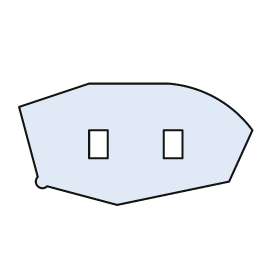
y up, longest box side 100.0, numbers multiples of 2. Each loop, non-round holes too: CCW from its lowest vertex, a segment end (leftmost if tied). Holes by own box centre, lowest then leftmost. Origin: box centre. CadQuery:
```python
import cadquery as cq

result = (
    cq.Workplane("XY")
    .moveTo(-8.0, -26.0)
    .lineTo(40.0, -16.0)
    .lineTo(50.0, 6.0)
    .threePointArc((34.0, 20.0), (14.0, 26.0))
    .lineTo(-20.0, 26.0)
    .lineTo(-50.0, 16.0)
    .lineTo(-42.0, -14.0)
    .threePointArc((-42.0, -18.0), (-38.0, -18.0))
    .close()
    .moveTo(-20.0, -6.0)
    .lineTo(-12.0, -6.0)
    .lineTo(-12.0, 6.0)
    .lineTo(-20.0, 6.0)
    .close()
    .moveTo(12.0, -6.0)
    .lineTo(20.0, -6.0)
    .lineTo(20.0, 6.0)
    .lineTo(12.0, 6.0)
    .close()
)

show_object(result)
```